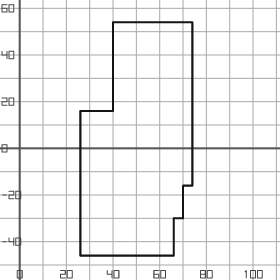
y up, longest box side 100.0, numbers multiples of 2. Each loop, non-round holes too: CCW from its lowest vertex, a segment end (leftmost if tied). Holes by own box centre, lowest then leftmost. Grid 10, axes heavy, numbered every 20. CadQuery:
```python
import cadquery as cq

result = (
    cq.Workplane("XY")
    .moveTo(26.0, -46.0)
    .lineTo(66.0, -46.0)
    .lineTo(66.0, -30.0)
    .lineTo(70.0, -30.0)
    .lineTo(70.0, -16.0)
    .lineTo(74.0, -16.0)
    .lineTo(74.0, 54.0)
    .lineTo(40.0, 54.0)
    .lineTo(40.0, 16.0)
    .lineTo(26.0, 16.0)
    .close()
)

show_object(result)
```